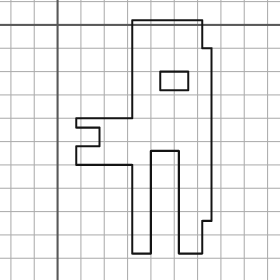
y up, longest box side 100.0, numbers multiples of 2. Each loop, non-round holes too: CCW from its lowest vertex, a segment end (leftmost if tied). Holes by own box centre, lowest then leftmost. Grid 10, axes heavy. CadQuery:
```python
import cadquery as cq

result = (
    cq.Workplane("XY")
    .moveTo(32.0, -98.0)
    .lineTo(40.0, -98.0)
    .lineTo(40.0, -54.0)
    .lineTo(52.0, -54.0)
    .lineTo(52.0, -98.0)
    .lineTo(62.0, -98.0)
    .lineTo(62.0, -84.0)
    .lineTo(66.0, -84.0)
    .lineTo(66.0, -10.0)
    .lineTo(62.0, -10.0)
    .lineTo(62.0, 2.0)
    .lineTo(32.0, 2.0)
    .lineTo(32.0, -40.0)
    .lineTo(8.0, -40.0)
    .lineTo(8.0, -44.0)
    .lineTo(18.0, -44.0)
    .lineTo(18.0, -52.0)
    .lineTo(8.0, -52.0)
    .lineTo(8.0, -60.0)
    .lineTo(32.0, -60.0)
    .close()
    .moveTo(44.0, -28.0)
    .lineTo(56.0, -28.0)
    .lineTo(56.0, -20.0)
    .lineTo(44.0, -20.0)
    .close()
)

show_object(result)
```